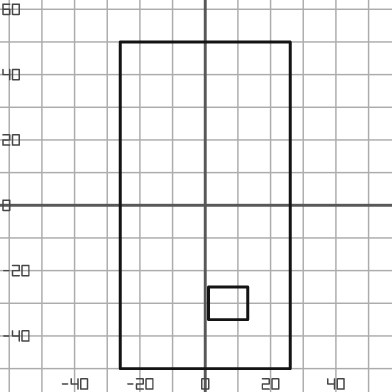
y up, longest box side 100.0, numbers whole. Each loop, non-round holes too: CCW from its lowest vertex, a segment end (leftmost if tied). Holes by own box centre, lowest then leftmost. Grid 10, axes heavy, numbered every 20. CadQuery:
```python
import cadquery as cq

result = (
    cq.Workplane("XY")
    .moveTo(-26.0, -50.0)
    .lineTo(26.0, -50.0)
    .lineTo(26.0, 50.0)
    .lineTo(-26.0, 50.0)
    .close()
    .moveTo(1.0, -35.0)
    .lineTo(13.0, -35.0)
    .lineTo(13.0, -25.0)
    .lineTo(1.0, -25.0)
    .close()
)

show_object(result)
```